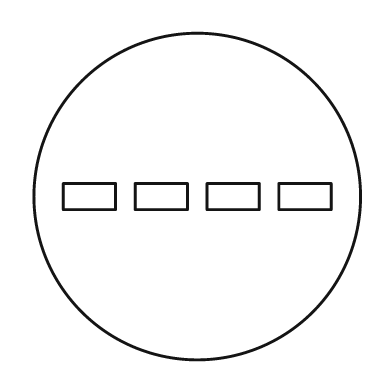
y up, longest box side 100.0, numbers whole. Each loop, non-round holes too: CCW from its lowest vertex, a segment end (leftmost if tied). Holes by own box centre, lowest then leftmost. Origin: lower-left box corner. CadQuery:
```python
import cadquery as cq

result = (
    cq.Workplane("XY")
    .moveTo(50.0, 50.0)
    .circle(50.0)
    .moveTo(9.0, 46.0)
    .lineTo(25.0, 46.0)
    .lineTo(25.0, 54.0)
    .lineTo(9.0, 54.0)
    .close()
    .moveTo(31.0, 46.0)
    .lineTo(47.0, 46.0)
    .lineTo(47.0, 54.0)
    .lineTo(31.0, 54.0)
    .close()
    .moveTo(53.0, 46.0)
    .lineTo(69.0, 46.0)
    .lineTo(69.0, 54.0)
    .lineTo(53.0, 54.0)
    .close()
    .moveTo(75.0, 46.0)
    .lineTo(91.0, 46.0)
    .lineTo(91.0, 54.0)
    .lineTo(75.0, 54.0)
    .close()
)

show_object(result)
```